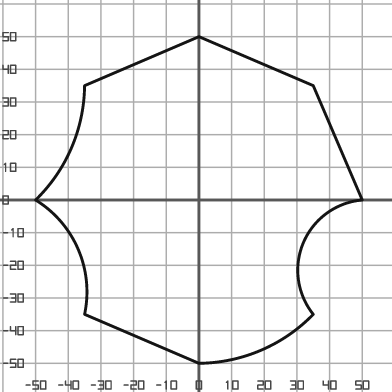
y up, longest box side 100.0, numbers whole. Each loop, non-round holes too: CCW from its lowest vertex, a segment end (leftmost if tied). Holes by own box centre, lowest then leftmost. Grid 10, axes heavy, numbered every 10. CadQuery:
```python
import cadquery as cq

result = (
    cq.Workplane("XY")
    .moveTo(0.0, -50.0)
    .threePointArc((19.0, -46.0), (35.0, -35.0))
    .threePointArc((32.0, -13.0), (50.0, 0.0))
    .lineTo(35.0, 35.0)
    .lineTo(0.0, 50.0)
    .lineTo(-35.0, 35.0)
    .threePointArc((-39.0, 16.0), (-50.0, 0.0))
    .threePointArc((-37.0, -15.0), (-35.0, -35.0))
    .close()
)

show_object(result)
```